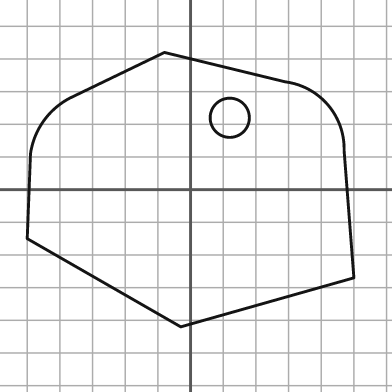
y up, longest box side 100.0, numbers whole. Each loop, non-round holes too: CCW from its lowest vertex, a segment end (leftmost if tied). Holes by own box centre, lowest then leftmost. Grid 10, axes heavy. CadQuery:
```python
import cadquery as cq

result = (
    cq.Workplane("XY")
    .moveTo(-3.0, -42.0)
    .lineTo(50.0, -27.0)
    .lineTo(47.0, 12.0)
    .threePointArc((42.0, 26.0), (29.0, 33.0))
    .lineTo(-8.0, 42.0)
    .lineTo(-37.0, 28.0)
    .threePointArc((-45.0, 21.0), (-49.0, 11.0))
    .lineTo(-50.0, -15.0)
    .close()
    .moveTo(12.0, 22.0)
    .circle(6.0)
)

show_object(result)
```